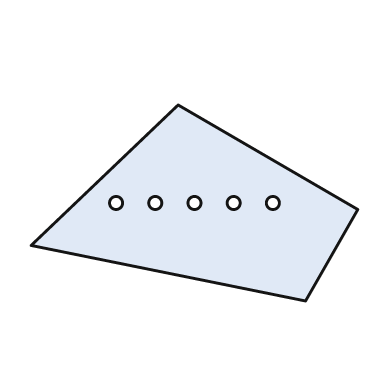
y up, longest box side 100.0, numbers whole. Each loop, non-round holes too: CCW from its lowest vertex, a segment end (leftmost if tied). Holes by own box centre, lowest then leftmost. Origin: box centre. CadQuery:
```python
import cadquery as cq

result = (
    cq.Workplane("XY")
    .moveTo(34.0, -30.0)
    .lineTo(50.0, -2.0)
    .lineTo(-5.0, 30.0)
    .lineTo(-50.0, -13.0)
    .close()
    .moveTo(-24.0, 0.0)
    .circle(2.0)
    .moveTo(-12.0, 0.0)
    .circle(2.0)
    .moveTo(0.0, 0.0)
    .circle(2.0)
    .moveTo(12.0, 0.0)
    .circle(2.0)
    .moveTo(24.0, 0.0)
    .circle(2.0)
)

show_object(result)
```